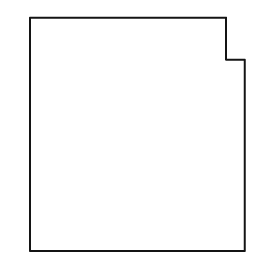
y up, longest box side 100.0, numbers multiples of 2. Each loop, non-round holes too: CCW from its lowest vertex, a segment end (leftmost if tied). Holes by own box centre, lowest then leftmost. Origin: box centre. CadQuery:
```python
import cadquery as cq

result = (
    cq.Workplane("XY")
    .moveTo(-46.0, -50.0)
    .lineTo(46.0, -50.0)
    .lineTo(46.0, 32.0)
    .lineTo(38.0, 32.0)
    .lineTo(38.0, 50.0)
    .lineTo(-46.0, 50.0)
    .close()
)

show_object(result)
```